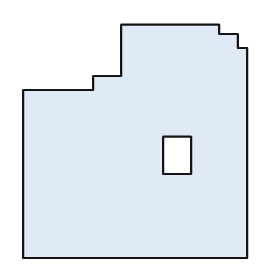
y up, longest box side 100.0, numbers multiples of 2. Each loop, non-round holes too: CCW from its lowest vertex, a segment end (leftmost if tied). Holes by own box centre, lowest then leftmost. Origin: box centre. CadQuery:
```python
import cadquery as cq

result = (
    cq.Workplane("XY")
    .moveTo(-48.0, -50.0)
    .lineTo(48.0, -50.0)
    .lineTo(48.0, 40.0)
    .lineTo(44.0, 40.0)
    .lineTo(44.0, 46.0)
    .lineTo(36.0, 46.0)
    .lineTo(36.0, 50.0)
    .lineTo(-6.0, 50.0)
    .lineTo(-6.0, 28.0)
    .lineTo(-18.0, 28.0)
    .lineTo(-18.0, 22.0)
    .lineTo(-48.0, 22.0)
    .close()
    .moveTo(12.0, -14.0)
    .lineTo(24.0, -14.0)
    .lineTo(24.0, 2.0)
    .lineTo(12.0, 2.0)
    .close()
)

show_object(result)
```